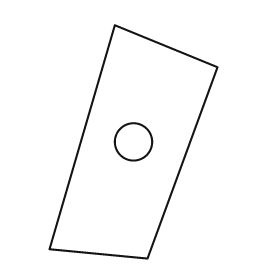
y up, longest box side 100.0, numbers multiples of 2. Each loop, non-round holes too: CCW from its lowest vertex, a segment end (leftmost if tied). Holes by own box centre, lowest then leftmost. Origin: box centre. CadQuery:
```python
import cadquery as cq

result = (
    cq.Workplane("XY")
    .moveTo(6.0, -50.0)
    .lineTo(36.0, 32.0)
    .lineTo(-8.0, 50.0)
    .lineTo(-36.0, -46.0)
    .close()
    .moveTo(0.0, 0.0)
    .circle(8.0)
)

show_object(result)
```